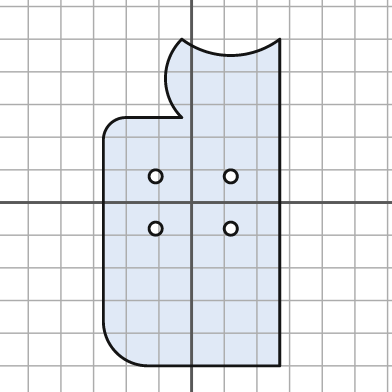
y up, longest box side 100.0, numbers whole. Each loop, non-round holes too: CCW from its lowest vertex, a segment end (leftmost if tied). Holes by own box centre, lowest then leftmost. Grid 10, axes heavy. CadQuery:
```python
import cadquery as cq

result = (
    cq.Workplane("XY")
    .moveTo(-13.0, -50.0)
    .lineTo(27.0, -50.0)
    .lineTo(27.0, 50.0)
    .threePointArc((12.0, 45.0), (-3.0, 50.0))
    .threePointArc((-8.0, 38.0), (-3.0, 26.0))
    .lineTo(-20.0, 26.0)
    .threePointArc((-25.0, 24.0), (-27.0, 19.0))
    .lineTo(-27.0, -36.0)
    .threePointArc((-23.0, -46.0), (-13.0, -50.0))
    .close()
    .moveTo(-11.0, -8.0)
    .circle(2.0)
    .moveTo(12.0, -8.0)
    .circle(2.0)
    .moveTo(-11.0, 8.0)
    .circle(2.0)
    .moveTo(12.0, 8.0)
    .circle(2.0)
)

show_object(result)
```